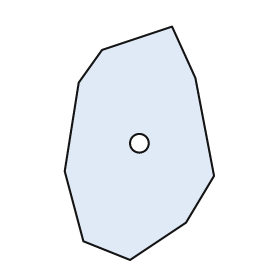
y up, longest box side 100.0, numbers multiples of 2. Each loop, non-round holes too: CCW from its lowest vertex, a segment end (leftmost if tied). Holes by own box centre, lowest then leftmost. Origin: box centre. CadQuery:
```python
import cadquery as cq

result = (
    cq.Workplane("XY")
    .moveTo(-4.0, -50.0)
    .lineTo(20.0, -34.0)
    .lineTo(32.0, -14.0)
    .lineTo(24.0, 28.0)
    .lineTo(14.0, 50.0)
    .lineTo(-16.0, 40.0)
    .lineTo(-26.0, 26.0)
    .lineTo(-32.0, -12.0)
    .lineTo(-24.0, -42.0)
    .close()
    .moveTo(0.0, 0.0)
    .circle(4.0)
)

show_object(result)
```